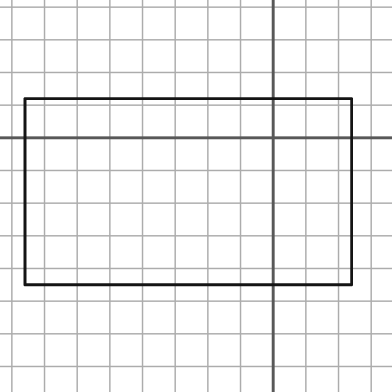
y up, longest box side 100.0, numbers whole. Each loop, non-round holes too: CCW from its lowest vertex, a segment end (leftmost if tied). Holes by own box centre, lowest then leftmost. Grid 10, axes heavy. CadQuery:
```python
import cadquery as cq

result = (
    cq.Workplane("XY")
    .moveTo(-76.0, -45.0)
    .lineTo(24.0, -45.0)
    .lineTo(24.0, 12.0)
    .lineTo(-76.0, 12.0)
    .close()
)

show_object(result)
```